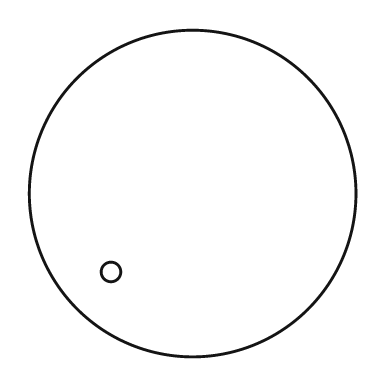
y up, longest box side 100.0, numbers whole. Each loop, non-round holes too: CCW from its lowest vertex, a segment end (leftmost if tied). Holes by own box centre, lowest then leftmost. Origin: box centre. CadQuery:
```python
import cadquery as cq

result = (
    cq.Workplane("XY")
    .moveTo(0.0, 0.0)
    .circle(50.0)
    .moveTo(-25.0, -24.0)
    .circle(3.0)
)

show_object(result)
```